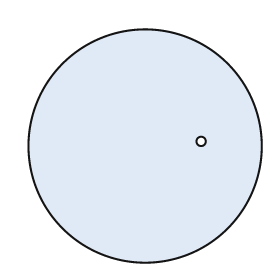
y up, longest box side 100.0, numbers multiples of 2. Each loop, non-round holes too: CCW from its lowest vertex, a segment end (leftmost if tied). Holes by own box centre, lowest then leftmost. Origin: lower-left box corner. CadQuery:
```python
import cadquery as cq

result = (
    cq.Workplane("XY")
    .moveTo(50.0, 50.0)
    .circle(50.0)
    .moveTo(74.0, 52.0)
    .circle(2.0)
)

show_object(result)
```